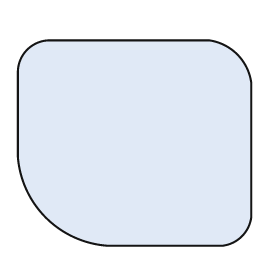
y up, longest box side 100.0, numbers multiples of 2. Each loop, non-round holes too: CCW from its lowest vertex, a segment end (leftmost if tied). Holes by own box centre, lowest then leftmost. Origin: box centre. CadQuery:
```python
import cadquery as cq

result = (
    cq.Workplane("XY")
    .moveTo(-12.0, -44.0)
    .lineTo(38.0, -44.0)
    .threePointArc((46.0, -40.0), (50.0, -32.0))
    .lineTo(50.0, 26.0)
    .threePointArc((44.0, 38.0), (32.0, 44.0))
    .lineTo(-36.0, 44.0)
    .threePointArc((-46.0, 40.0), (-50.0, 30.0))
    .lineTo(-50.0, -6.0)
    .threePointArc((-38.0, -32.0), (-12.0, -44.0))
    .close()
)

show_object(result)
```